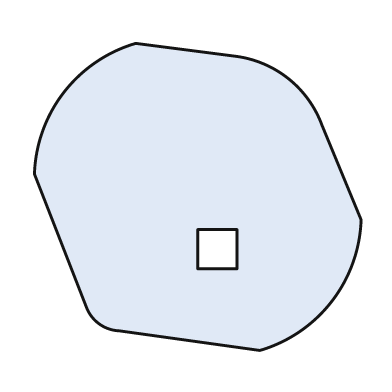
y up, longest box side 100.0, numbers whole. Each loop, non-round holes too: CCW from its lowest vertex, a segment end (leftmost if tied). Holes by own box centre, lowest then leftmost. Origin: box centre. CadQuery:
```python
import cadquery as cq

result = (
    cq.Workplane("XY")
    .moveTo(19.0, -47.0)
    .threePointArc((41.0, -32.0), (50.0, -7.0))
    .lineTo(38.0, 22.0)
    .threePointArc((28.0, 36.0), (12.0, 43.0))
    .lineTo(-19.0, 47.0)
    .threePointArc((-41.0, 32.0), (-50.0, 7.0))
    .lineTo(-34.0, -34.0)
    .threePointArc((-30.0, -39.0), (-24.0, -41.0))
    .close()
    .moveTo(0.0, -22.0)
    .lineTo(12.0, -22.0)
    .lineTo(12.0, -10.0)
    .lineTo(0.0, -10.0)
    .close()
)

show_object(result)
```